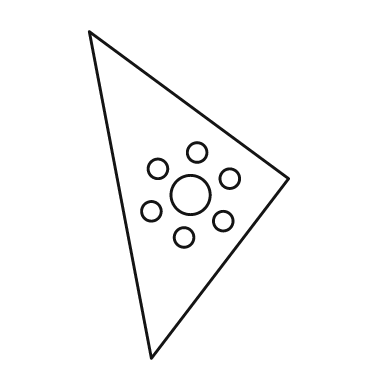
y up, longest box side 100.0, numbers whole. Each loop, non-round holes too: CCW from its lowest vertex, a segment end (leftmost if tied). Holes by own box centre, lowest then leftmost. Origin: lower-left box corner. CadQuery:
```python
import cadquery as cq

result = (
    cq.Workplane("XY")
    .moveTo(19.0, 0.0)
    .lineTo(61.0, 55.0)
    .lineTo(0.0, 100.0)
    .close()
    .moveTo(29.0, 37.0)
    .circle(3.0)
    .moveTo(41.0, 42.0)
    .circle(3.0)
    .moveTo(19.0, 45.0)
    .circle(3.0)
    .moveTo(31.0, 50.0)
    .circle(6.0)
    .moveTo(43.0, 55.0)
    .circle(3.0)
    .moveTo(21.0, 58.0)
    .circle(3.0)
    .moveTo(33.0, 63.0)
    .circle(3.0)
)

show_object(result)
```